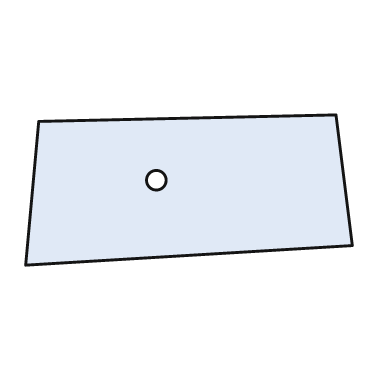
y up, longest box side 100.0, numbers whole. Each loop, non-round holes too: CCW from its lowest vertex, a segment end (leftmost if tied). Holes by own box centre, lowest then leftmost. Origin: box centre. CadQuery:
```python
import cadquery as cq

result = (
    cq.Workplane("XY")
    .moveTo(-50.0, -23.0)
    .lineTo(50.0, -17.0)
    .lineTo(45.0, 23.0)
    .lineTo(-46.0, 21.0)
    .close()
    .moveTo(-10.0, 3.0)
    .circle(3.0)
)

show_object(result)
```